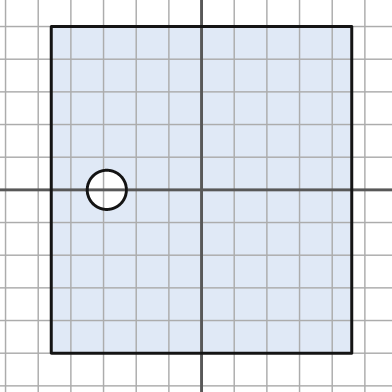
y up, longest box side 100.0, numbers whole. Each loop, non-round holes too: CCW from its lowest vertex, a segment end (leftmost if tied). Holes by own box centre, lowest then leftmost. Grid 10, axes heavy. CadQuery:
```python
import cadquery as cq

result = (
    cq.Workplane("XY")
    .moveTo(-46.0, -50.0)
    .lineTo(46.0, -50.0)
    .lineTo(46.0, 50.0)
    .lineTo(-46.0, 50.0)
    .close()
    .moveTo(-29.0, 0.0)
    .circle(6.0)
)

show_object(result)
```